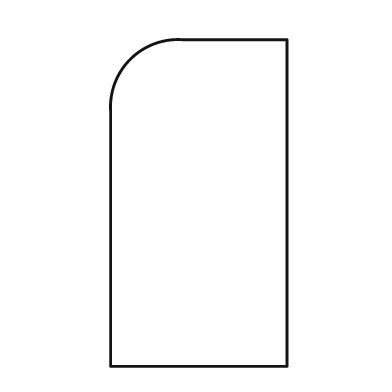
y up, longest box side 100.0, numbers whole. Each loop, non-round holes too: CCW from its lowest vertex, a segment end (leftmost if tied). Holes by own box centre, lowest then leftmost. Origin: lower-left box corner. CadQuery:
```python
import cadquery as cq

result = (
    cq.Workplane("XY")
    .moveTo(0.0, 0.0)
    .lineTo(54.0, 0.0)
    .lineTo(54.0, 100.0)
    .lineTo(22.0, 100.0)
    .threePointArc((6.0, 94.0), (0.0, 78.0))
    .close()
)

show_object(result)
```